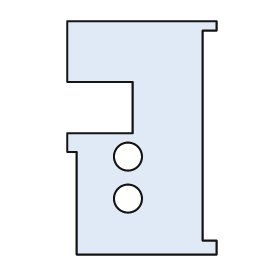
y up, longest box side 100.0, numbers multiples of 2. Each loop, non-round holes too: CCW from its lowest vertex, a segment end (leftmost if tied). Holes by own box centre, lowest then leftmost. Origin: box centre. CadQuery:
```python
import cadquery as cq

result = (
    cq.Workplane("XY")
    .moveTo(-28.0, -50.0)
    .lineTo(32.0, -50.0)
    .lineTo(32.0, -44.0)
    .lineTo(26.0, -44.0)
    .lineTo(26.0, 46.0)
    .lineTo(32.0, 46.0)
    .lineTo(32.0, 50.0)
    .lineTo(-32.0, 50.0)
    .lineTo(-32.0, 24.0)
    .lineTo(-4.0, 24.0)
    .lineTo(-4.0, 2.0)
    .lineTo(-32.0, 2.0)
    .lineTo(-32.0, -6.0)
    .lineTo(-28.0, -6.0)
    .close()
    .moveTo(-6.0, -26.0)
    .circle(6.0)
    .moveTo(-6.0, -8.0)
    .circle(6.0)
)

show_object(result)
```